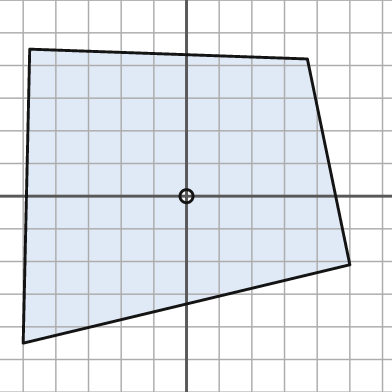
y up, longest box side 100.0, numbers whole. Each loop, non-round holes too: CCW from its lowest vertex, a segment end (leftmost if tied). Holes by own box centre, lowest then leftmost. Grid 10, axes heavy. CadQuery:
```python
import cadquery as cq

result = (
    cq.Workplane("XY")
    .moveTo(-50.0, -45.0)
    .lineTo(50.0, -21.0)
    .lineTo(37.0, 42.0)
    .lineTo(-48.0, 45.0)
    .close()
    .moveTo(0.0, 0.0)
    .circle(2.0)
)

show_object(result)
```